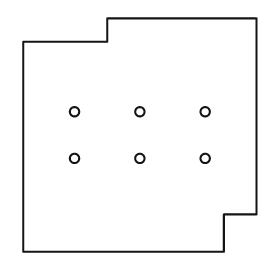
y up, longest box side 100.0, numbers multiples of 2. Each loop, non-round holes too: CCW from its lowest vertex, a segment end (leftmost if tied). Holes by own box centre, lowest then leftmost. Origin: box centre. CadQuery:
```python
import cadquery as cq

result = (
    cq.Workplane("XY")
    .moveTo(-50.0, -50.0)
    .lineTo(36.0, -50.0)
    .lineTo(36.0, -34.0)
    .lineTo(50.0, -34.0)
    .lineTo(50.0, 50.0)
    .lineTo(-14.0, 50.0)
    .lineTo(-14.0, 40.0)
    .lineTo(-50.0, 40.0)
    .close()
    .moveTo(-28.0, -10.0)
    .circle(2.0)
    .moveTo(0.0, -10.0)
    .circle(2.0)
    .moveTo(28.0, -10.0)
    .circle(2.0)
    .moveTo(-28.0, 10.0)
    .circle(2.0)
    .moveTo(0.0, 10.0)
    .circle(2.0)
    .moveTo(28.0, 10.0)
    .circle(2.0)
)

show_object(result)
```